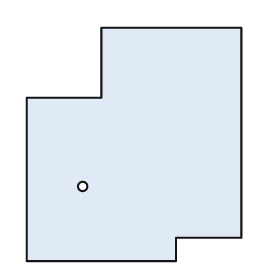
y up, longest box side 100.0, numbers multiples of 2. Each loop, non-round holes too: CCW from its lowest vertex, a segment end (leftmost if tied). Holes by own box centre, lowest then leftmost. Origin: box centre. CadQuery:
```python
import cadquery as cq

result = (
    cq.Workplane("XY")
    .moveTo(-46.0, -50.0)
    .lineTo(18.0, -50.0)
    .lineTo(18.0, -40.0)
    .lineTo(46.0, -40.0)
    .lineTo(46.0, 50.0)
    .lineTo(-14.0, 50.0)
    .lineTo(-14.0, 20.0)
    .lineTo(-46.0, 20.0)
    .close()
    .moveTo(-22.0, -18.0)
    .circle(2.0)
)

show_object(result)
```